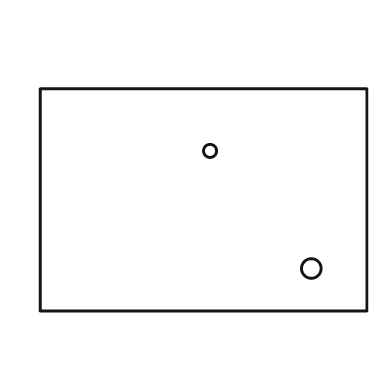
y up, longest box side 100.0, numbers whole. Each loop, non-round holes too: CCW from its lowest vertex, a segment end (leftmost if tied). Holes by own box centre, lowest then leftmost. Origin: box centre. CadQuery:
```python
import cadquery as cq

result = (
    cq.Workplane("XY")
    .moveTo(-50.0, -34.0)
    .lineTo(50.0, -34.0)
    .lineTo(50.0, 34.0)
    .lineTo(-50.0, 34.0)
    .close()
    .moveTo(33.0, -21.0)
    .circle(3.0)
    .moveTo(2.0, 15.0)
    .circle(2.0)
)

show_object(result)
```